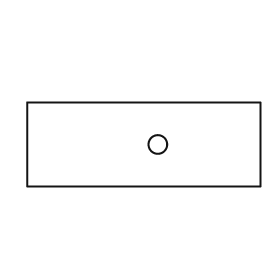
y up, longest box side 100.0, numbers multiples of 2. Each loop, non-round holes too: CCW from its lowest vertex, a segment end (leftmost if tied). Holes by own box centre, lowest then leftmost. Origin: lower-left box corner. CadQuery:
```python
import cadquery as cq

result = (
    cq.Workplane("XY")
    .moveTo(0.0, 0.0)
    .lineTo(100.0, 0.0)
    .lineTo(100.0, 36.0)
    .lineTo(0.0, 36.0)
    .close()
    .moveTo(56.0, 18.0)
    .circle(4.0)
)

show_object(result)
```